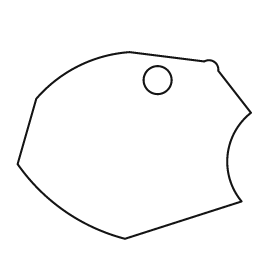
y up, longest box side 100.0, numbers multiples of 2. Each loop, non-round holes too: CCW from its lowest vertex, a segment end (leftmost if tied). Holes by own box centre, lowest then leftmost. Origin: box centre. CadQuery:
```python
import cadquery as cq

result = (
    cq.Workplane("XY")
    .moveTo(-4.0, -40.0)
    .lineTo(46.0, -24.0)
    .threePointArc((40.0, -4.0), (50.0, 14.0))
    .lineTo(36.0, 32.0)
    .threePointArc((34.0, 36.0), (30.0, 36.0))
    .lineTo(-2.0, 40.0)
    .threePointArc((-24.0, 34.0), (-42.0, 20.0))
    .lineTo(-50.0, -8.0)
    .threePointArc((-30.0, -28.0), (-4.0, -40.0))
    .close()
    .moveTo(10.0, 28.0)
    .circle(6.0)
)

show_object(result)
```